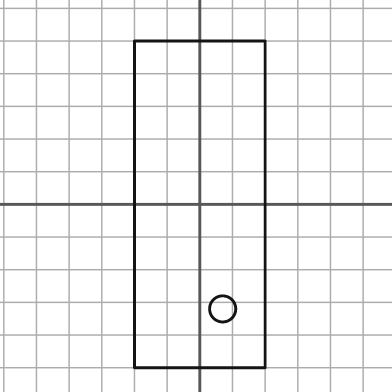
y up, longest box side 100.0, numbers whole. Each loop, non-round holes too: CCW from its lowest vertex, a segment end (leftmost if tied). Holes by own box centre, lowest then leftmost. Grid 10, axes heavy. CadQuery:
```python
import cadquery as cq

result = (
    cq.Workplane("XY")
    .moveTo(-20.0, -50.0)
    .lineTo(20.0, -50.0)
    .lineTo(20.0, 50.0)
    .lineTo(-20.0, 50.0)
    .close()
    .moveTo(7.0, -32.0)
    .circle(4.0)
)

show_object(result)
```